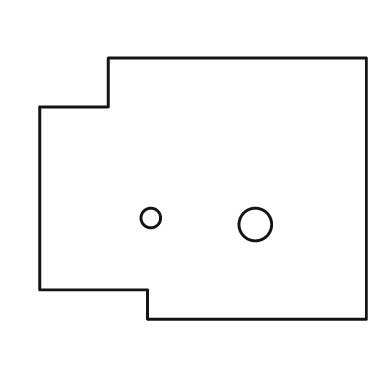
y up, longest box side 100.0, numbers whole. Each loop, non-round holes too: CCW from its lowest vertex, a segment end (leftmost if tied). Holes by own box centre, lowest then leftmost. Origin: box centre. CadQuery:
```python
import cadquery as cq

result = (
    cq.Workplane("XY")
    .moveTo(-17.0, -40.0)
    .lineTo(50.0, -40.0)
    .lineTo(50.0, 40.0)
    .lineTo(-29.0, 40.0)
    .lineTo(-29.0, 25.0)
    .lineTo(-50.0, 25.0)
    .lineTo(-50.0, -31.0)
    .lineTo(-17.0, -31.0)
    .close()
    .moveTo(16.0, -11.0)
    .circle(5.0)
    .moveTo(-16.0, -9.0)
    .circle(3.0)
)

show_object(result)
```